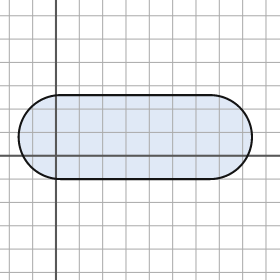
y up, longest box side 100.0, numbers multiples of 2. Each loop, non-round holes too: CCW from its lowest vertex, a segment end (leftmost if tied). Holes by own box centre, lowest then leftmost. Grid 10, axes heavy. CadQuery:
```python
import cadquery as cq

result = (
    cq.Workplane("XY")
    .moveTo(2.0, -10.0)
    .lineTo(66.0, -10.0)
    .threePointArc((84.0, 8.0), (66.0, 26.0))
    .lineTo(2.0, 26.0)
    .threePointArc((-16.0, 8.0), (2.0, -10.0))
    .close()
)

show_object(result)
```